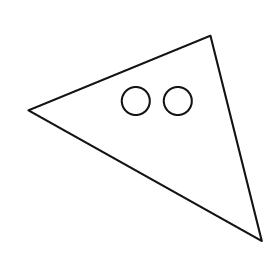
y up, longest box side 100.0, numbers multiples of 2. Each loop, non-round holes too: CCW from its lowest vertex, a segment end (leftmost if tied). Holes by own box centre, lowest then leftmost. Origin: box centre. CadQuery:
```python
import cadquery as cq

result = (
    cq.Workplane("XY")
    .moveTo(50.0, -44.0)
    .lineTo(28.0, 44.0)
    .lineTo(-50.0, 12.0)
    .close()
    .moveTo(-4.0, 16.0)
    .circle(6.0)
    .moveTo(14.0, 16.0)
    .circle(6.0)
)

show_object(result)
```